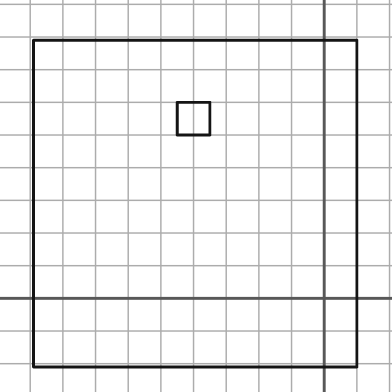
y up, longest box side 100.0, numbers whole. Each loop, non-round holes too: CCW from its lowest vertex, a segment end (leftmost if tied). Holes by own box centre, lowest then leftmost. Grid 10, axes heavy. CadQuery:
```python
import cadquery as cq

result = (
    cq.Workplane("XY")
    .moveTo(-89.0, -21.0)
    .lineTo(10.0, -21.0)
    .lineTo(10.0, 79.0)
    .lineTo(-89.0, 79.0)
    .close()
    .moveTo(-45.0, 50.0)
    .lineTo(-35.0, 50.0)
    .lineTo(-35.0, 60.0)
    .lineTo(-45.0, 60.0)
    .close()
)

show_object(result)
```